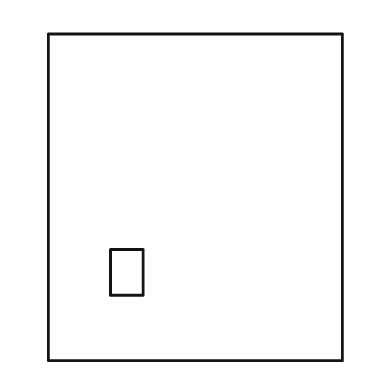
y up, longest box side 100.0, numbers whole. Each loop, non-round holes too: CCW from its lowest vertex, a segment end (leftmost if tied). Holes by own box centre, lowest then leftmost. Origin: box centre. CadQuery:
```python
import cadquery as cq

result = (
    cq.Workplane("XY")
    .moveTo(-45.0, -50.0)
    .lineTo(45.0, -50.0)
    .lineTo(45.0, 50.0)
    .lineTo(-45.0, 50.0)
    .close()
    .moveTo(-26.0, -30.0)
    .lineTo(-16.0, -30.0)
    .lineTo(-16.0, -16.0)
    .lineTo(-26.0, -16.0)
    .close()
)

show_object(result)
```